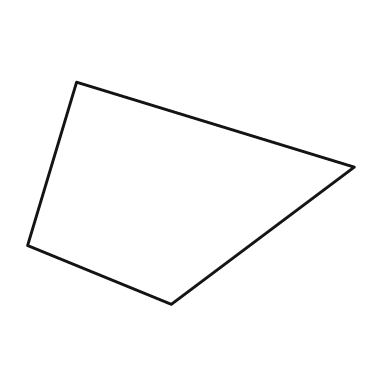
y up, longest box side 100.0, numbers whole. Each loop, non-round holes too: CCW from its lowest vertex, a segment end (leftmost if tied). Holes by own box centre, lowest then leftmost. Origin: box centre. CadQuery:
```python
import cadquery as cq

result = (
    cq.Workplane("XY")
    .moveTo(-6.0, -34.0)
    .lineTo(50.0, 8.0)
    .lineTo(-35.0, 34.0)
    .lineTo(-50.0, -16.0)
    .close()
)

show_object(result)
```